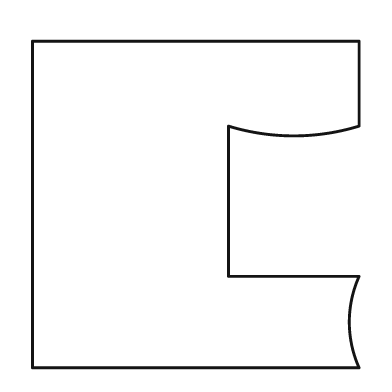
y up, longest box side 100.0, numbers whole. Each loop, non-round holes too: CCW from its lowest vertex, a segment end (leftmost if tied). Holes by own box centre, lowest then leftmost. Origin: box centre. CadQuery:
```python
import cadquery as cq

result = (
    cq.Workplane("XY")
    .moveTo(-50.0, -50.0)
    .lineTo(50.0, -50.0)
    .threePointArc((47.0, -36.0), (50.0, -22.0))
    .lineTo(10.0, -22.0)
    .lineTo(10.0, 24.0)
    .threePointArc((30.0, 21.0), (50.0, 24.0))
    .lineTo(50.0, 50.0)
    .lineTo(-50.0, 50.0)
    .close()
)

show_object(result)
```